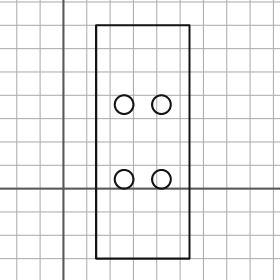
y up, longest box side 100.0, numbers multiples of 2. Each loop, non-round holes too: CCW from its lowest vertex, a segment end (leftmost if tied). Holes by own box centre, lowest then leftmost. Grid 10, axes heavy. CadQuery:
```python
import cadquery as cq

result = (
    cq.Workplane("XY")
    .moveTo(14.0, -30.0)
    .lineTo(54.0, -30.0)
    .lineTo(54.0, 70.0)
    .lineTo(14.0, 70.0)
    .close()
    .moveTo(26.0, 4.0)
    .circle(4.0)
    .moveTo(42.0, 4.0)
    .circle(4.0)
    .moveTo(26.0, 36.0)
    .circle(4.0)
    .moveTo(42.0, 36.0)
    .circle(4.0)
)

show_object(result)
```